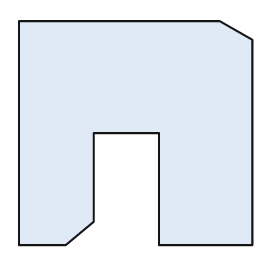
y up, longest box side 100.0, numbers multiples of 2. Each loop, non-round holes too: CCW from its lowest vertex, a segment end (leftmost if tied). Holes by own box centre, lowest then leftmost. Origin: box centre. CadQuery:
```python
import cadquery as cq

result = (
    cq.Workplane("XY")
    .moveTo(-50.0, -48.0)
    .lineTo(-30.0, -48.0)
    .lineTo(-18.0, -38.0)
    .lineTo(-18.0, 0.0)
    .lineTo(10.0, 0.0)
    .lineTo(10.0, -48.0)
    .lineTo(50.0, -48.0)
    .lineTo(50.0, 40.0)
    .lineTo(36.0, 48.0)
    .lineTo(-50.0, 48.0)
    .close()
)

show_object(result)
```